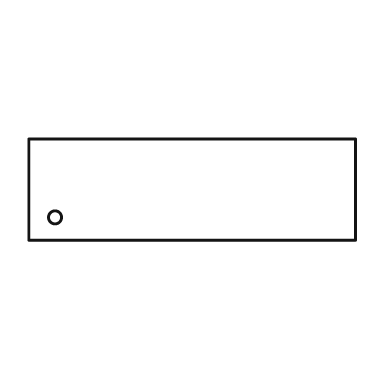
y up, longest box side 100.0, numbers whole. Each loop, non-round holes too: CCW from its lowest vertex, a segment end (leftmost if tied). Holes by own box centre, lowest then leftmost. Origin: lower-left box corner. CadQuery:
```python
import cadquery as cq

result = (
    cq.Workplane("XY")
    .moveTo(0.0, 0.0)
    .lineTo(100.0, 0.0)
    .lineTo(100.0, 31.0)
    .lineTo(0.0, 31.0)
    .close()
    .moveTo(8.0, 7.0)
    .circle(2.0)
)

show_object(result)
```